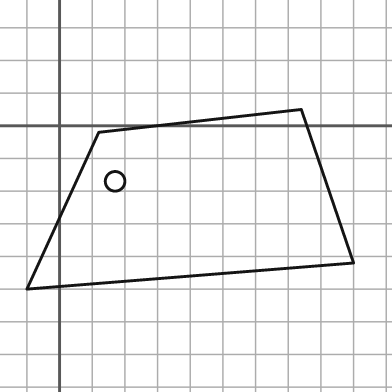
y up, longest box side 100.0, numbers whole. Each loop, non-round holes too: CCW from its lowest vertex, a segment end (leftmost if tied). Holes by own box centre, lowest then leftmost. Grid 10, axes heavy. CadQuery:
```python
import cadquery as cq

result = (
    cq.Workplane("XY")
    .moveTo(-10.0, -50.0)
    .lineTo(90.0, -42.0)
    .lineTo(74.0, 5.0)
    .lineTo(12.0, -2.0)
    .close()
    .moveTo(17.0, -17.0)
    .circle(3.0)
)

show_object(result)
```